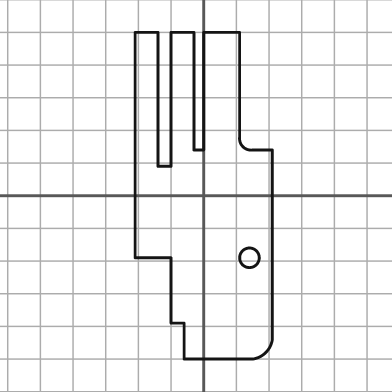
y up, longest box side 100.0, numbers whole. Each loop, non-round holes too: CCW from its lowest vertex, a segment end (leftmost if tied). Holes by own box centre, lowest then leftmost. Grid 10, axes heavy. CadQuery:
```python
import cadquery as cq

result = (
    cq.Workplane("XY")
    .moveTo(-6.0, -50.0)
    .lineTo(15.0, -50.0)
    .threePointArc((19.0, -48.0), (21.0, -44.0))
    .lineTo(21.0, 14.0)
    .lineTo(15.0, 14.0)
    .threePointArc((12.0, 15.0), (11.0, 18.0))
    .lineTo(11.0, 50.0)
    .lineTo(0.0, 50.0)
    .lineTo(0.0, 14.0)
    .lineTo(-3.0, 14.0)
    .lineTo(-3.0, 50.0)
    .lineTo(-10.0, 50.0)
    .lineTo(-10.0, 9.0)
    .lineTo(-14.0, 9.0)
    .lineTo(-14.0, 50.0)
    .lineTo(-21.0, 50.0)
    .lineTo(-21.0, -19.0)
    .lineTo(-10.0, -19.0)
    .lineTo(-10.0, -39.0)
    .lineTo(-6.0, -39.0)
    .close()
    .moveTo(14.0, -19.0)
    .circle(3.0)
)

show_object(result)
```